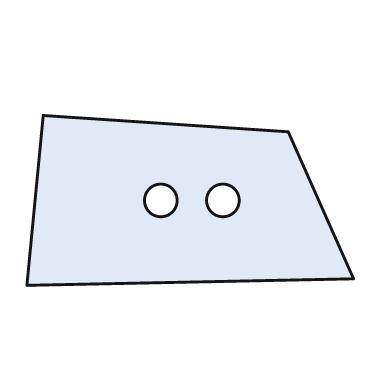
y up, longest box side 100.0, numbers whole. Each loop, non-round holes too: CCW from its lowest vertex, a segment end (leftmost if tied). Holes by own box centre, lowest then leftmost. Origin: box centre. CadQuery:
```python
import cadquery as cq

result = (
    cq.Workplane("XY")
    .moveTo(-50.0, -26.0)
    .lineTo(50.0, -24.0)
    .lineTo(30.0, 21.0)
    .lineTo(-45.0, 26.0)
    .close()
    .moveTo(-9.0, 0.0)
    .circle(5.0)
    .moveTo(10.0, 0.0)
    .circle(5.0)
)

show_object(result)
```